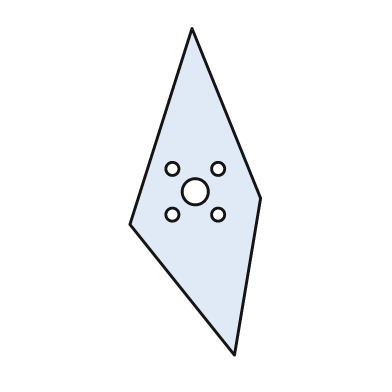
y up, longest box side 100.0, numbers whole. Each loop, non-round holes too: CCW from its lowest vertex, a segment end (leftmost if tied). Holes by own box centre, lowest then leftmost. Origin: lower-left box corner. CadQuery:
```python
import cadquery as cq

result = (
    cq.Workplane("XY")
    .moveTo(32.0, 0.0)
    .lineTo(40.0, 48.0)
    .lineTo(19.0, 100.0)
    .lineTo(0.0, 40.0)
    .close()
    .moveTo(13.0, 43.0)
    .circle(2.0)
    .moveTo(27.0, 43.0)
    .circle(2.0)
    .moveTo(20.0, 50.0)
    .circle(4.0)
    .moveTo(13.0, 57.0)
    .circle(2.0)
    .moveTo(27.0, 57.0)
    .circle(2.0)
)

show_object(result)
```